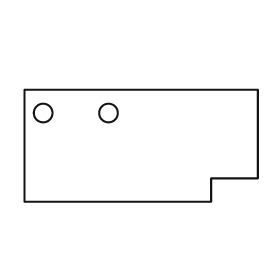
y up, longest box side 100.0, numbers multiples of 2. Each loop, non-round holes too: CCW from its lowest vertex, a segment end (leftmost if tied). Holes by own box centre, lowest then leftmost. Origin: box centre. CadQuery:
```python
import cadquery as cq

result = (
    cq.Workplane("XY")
    .moveTo(-50.0, -24.0)
    .lineTo(30.0, -24.0)
    .lineTo(30.0, -14.0)
    .lineTo(50.0, -14.0)
    .lineTo(50.0, 24.0)
    .lineTo(-50.0, 24.0)
    .close()
    .moveTo(-42.0, 14.0)
    .circle(4.0)
    .moveTo(-14.0, 14.0)
    .circle(4.0)
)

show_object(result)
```